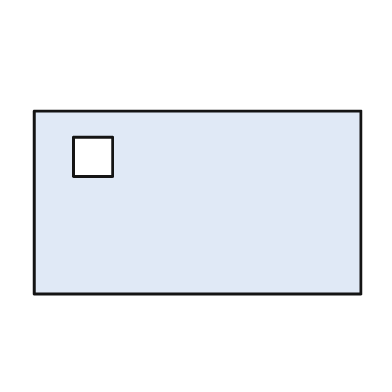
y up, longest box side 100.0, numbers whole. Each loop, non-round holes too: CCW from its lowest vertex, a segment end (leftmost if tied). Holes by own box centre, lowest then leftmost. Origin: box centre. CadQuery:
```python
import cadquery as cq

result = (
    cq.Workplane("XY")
    .moveTo(-50.0, -28.0)
    .lineTo(50.0, -28.0)
    .lineTo(50.0, 28.0)
    .lineTo(-50.0, 28.0)
    .close()
    .moveTo(-38.0, 8.0)
    .lineTo(-26.0, 8.0)
    .lineTo(-26.0, 20.0)
    .lineTo(-38.0, 20.0)
    .close()
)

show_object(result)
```